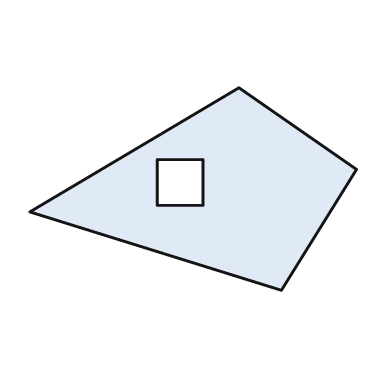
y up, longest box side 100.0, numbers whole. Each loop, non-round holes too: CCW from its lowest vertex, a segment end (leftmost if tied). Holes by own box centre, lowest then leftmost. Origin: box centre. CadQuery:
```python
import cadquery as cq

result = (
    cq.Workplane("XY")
    .moveTo(27.0, -31.0)
    .lineTo(50.0, 6.0)
    .lineTo(14.0, 31.0)
    .lineTo(-50.0, -7.0)
    .close()
    .moveTo(-11.0, -5.0)
    .lineTo(3.0, -5.0)
    .lineTo(3.0, 9.0)
    .lineTo(-11.0, 9.0)
    .close()
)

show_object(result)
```